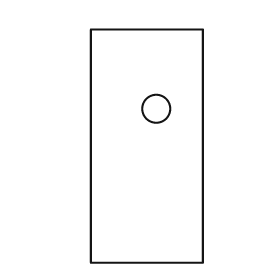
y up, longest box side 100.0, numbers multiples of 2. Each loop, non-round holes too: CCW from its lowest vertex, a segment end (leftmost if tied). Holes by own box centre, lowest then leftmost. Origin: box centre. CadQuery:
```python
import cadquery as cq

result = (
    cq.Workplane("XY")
    .moveTo(-24.0, -50.0)
    .lineTo(24.0, -50.0)
    .lineTo(24.0, 50.0)
    .lineTo(-24.0, 50.0)
    .close()
    .moveTo(4.0, 16.0)
    .circle(6.0)
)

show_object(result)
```